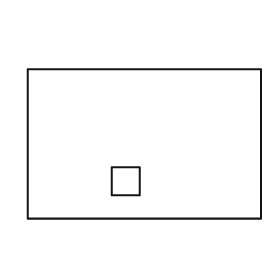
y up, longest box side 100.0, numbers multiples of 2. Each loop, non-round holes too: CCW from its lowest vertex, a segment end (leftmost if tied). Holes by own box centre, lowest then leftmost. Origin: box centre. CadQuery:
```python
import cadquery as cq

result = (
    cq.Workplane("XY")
    .moveTo(-50.0, -32.0)
    .lineTo(50.0, -32.0)
    .lineTo(50.0, 32.0)
    .lineTo(-50.0, 32.0)
    .close()
    .moveTo(-14.0, -22.0)
    .lineTo(-2.0, -22.0)
    .lineTo(-2.0, -10.0)
    .lineTo(-14.0, -10.0)
    .close()
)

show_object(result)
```